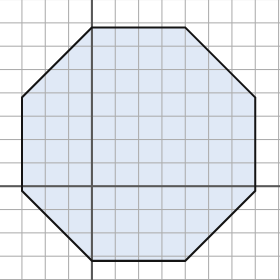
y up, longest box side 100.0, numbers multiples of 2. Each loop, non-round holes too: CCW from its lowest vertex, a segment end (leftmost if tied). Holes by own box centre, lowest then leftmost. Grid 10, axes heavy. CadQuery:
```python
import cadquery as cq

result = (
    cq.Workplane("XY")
    .moveTo(0.0, -32.0)
    .lineTo(40.0, -32.0)
    .lineTo(70.0, -2.0)
    .lineTo(70.0, 38.0)
    .lineTo(40.0, 68.0)
    .lineTo(0.0, 68.0)
    .lineTo(-30.0, 38.0)
    .lineTo(-30.0, -2.0)
    .close()
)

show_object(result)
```